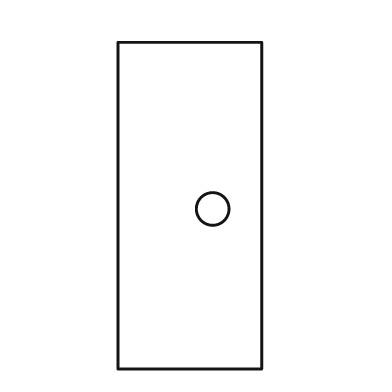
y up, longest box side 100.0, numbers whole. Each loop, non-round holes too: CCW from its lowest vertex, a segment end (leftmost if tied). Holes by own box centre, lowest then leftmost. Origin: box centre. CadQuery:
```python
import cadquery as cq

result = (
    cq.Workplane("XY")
    .moveTo(-22.0, -50.0)
    .lineTo(22.0, -50.0)
    .lineTo(22.0, 50.0)
    .lineTo(-22.0, 50.0)
    .close()
    .moveTo(7.0, -1.0)
    .circle(5.0)
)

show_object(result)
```